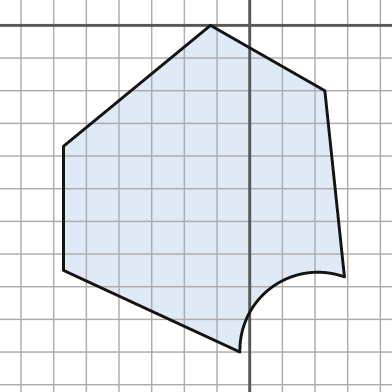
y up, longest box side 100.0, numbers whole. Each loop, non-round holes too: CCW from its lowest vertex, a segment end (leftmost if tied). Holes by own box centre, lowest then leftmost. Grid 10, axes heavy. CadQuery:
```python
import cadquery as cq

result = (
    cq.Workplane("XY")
    .moveTo(-3.0, -100.0)
    .threePointArc((7.0, -80.0), (29.0, -77.0))
    .lineTo(23.0, -20.0)
    .lineTo(-12.0, 0.0)
    .lineTo(-57.0, -37.0)
    .lineTo(-57.0, -75.0)
    .close()
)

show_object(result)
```